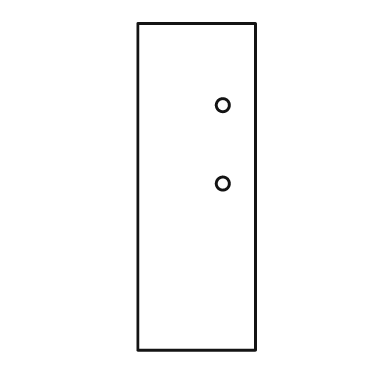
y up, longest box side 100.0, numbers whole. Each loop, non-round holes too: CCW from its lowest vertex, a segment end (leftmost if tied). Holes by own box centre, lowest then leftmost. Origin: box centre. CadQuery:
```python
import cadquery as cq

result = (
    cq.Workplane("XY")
    .moveTo(-18.0, -50.0)
    .lineTo(18.0, -50.0)
    .lineTo(18.0, 50.0)
    .lineTo(-18.0, 50.0)
    .close()
    .moveTo(8.0, 1.0)
    .circle(2.0)
    .moveTo(8.0, 25.0)
    .circle(2.0)
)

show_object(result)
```